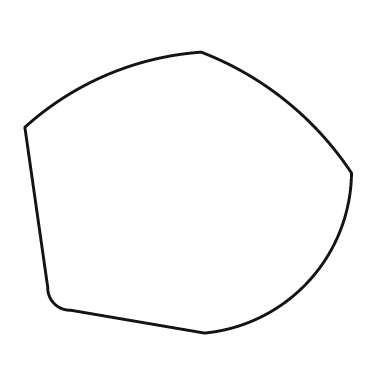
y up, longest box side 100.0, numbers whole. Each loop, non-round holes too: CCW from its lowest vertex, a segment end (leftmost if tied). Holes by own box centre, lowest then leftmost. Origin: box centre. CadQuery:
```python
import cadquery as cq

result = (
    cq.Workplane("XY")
    .moveTo(5.0, -43.0)
    .threePointArc((37.0, -27.0), (50.0, 6.0))
    .threePointArc((30.0, 28.0), (4.0, 43.0))
    .threePointArc((-25.0, 36.0), (-50.0, 20.0))
    .lineTo(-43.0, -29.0)
    .threePointArc((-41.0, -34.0), (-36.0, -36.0))
    .close()
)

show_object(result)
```